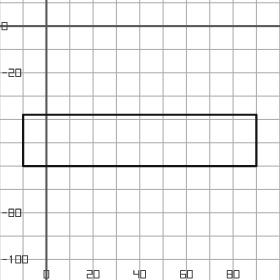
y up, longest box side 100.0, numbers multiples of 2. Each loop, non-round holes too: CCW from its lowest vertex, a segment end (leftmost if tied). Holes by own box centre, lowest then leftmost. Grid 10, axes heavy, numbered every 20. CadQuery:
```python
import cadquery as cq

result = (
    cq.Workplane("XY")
    .moveTo(-10.0, -60.0)
    .lineTo(90.0, -60.0)
    .lineTo(90.0, -38.0)
    .lineTo(-10.0, -38.0)
    .close()
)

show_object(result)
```